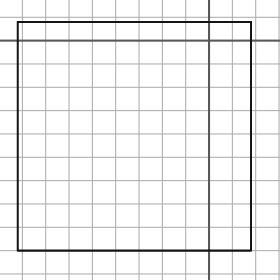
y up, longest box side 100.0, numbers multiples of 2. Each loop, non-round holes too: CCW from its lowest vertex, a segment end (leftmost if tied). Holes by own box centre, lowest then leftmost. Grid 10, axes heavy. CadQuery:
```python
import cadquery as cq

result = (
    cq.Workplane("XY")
    .moveTo(-82.0, -90.0)
    .lineTo(18.0, -90.0)
    .lineTo(18.0, 8.0)
    .lineTo(-82.0, 8.0)
    .close()
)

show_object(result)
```